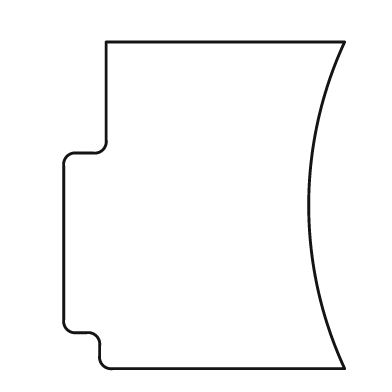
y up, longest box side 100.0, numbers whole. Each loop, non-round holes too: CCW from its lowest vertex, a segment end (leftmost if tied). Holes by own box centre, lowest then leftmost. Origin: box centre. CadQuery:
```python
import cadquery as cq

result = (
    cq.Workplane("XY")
    .moveTo(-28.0, -50.0)
    .lineTo(43.0, -50.0)
    .threePointArc((32.0, 0.0), (43.0, 50.0))
    .lineTo(-30.0, 50.0)
    .lineTo(-30.0, 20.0)
    .threePointArc((-31.0, 17.0), (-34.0, 16.0))
    .lineTo(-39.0, 16.0)
    .threePointArc((-42.0, 15.0), (-43.0, 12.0))
    .lineTo(-43.0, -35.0)
    .threePointArc((-42.0, -38.0), (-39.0, -39.0))
    .lineTo(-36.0, -39.0)
    .threePointArc((-33.0, -40.0), (-32.0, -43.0))
    .lineTo(-32.0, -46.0)
    .threePointArc((-31.0, -49.0), (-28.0, -50.0))
    .close()
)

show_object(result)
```